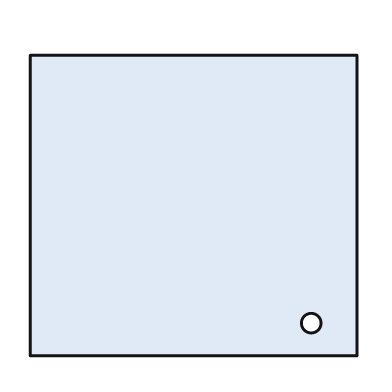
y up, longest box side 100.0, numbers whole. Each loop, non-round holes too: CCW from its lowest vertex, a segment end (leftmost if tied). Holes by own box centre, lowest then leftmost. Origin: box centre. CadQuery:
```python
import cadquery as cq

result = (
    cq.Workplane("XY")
    .moveTo(-50.0, -46.0)
    .lineTo(50.0, -46.0)
    .lineTo(50.0, 46.0)
    .lineTo(-50.0, 46.0)
    .close()
    .moveTo(36.0, -36.0)
    .circle(3.0)
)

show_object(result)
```